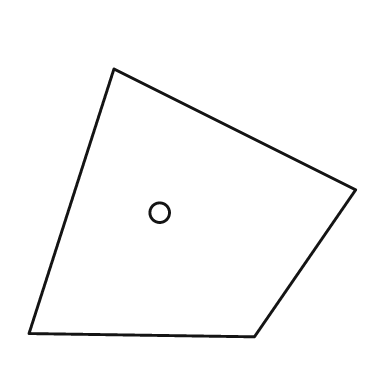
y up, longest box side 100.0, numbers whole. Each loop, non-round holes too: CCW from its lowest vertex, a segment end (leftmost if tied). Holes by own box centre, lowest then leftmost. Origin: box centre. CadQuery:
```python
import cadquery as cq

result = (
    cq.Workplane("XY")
    .moveTo(19.0, -41.0)
    .lineTo(50.0, 4.0)
    .lineTo(-24.0, 41.0)
    .lineTo(-50.0, -40.0)
    .close()
    .moveTo(-10.0, -3.0)
    .circle(3.0)
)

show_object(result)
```